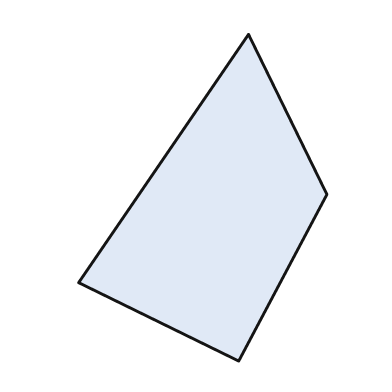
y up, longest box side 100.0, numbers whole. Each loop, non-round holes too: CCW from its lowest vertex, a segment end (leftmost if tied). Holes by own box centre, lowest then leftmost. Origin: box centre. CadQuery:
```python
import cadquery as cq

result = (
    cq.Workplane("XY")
    .moveTo(11.0, -50.0)
    .lineTo(38.0, 1.0)
    .lineTo(14.0, 50.0)
    .lineTo(-38.0, -26.0)
    .close()
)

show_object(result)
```